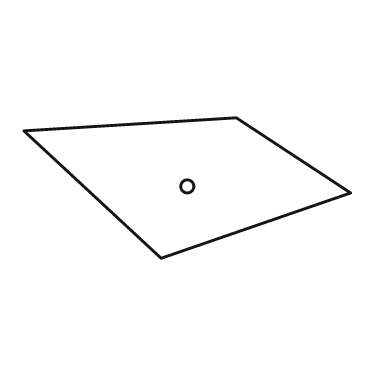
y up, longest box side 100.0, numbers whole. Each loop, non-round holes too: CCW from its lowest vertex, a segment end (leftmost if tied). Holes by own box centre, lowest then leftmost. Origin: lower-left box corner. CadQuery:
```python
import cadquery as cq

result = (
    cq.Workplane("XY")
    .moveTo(42.0, 0.0)
    .lineTo(100.0, 20.0)
    .lineTo(65.0, 43.0)
    .lineTo(0.0, 39.0)
    .close()
    .moveTo(50.0, 22.0)
    .circle(2.0)
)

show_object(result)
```